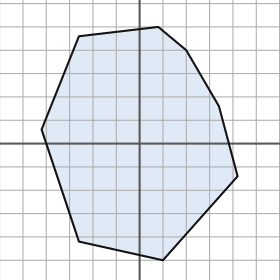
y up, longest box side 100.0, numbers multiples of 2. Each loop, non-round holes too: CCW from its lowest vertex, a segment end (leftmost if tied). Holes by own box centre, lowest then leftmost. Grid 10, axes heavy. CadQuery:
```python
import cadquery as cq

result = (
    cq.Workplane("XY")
    .moveTo(10.0, -50.0)
    .lineTo(42.0, -14.0)
    .lineTo(34.0, 16.0)
    .lineTo(20.0, 40.0)
    .lineTo(8.0, 50.0)
    .lineTo(-26.0, 46.0)
    .lineTo(-42.0, 6.0)
    .lineTo(-26.0, -42.0)
    .close()
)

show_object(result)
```